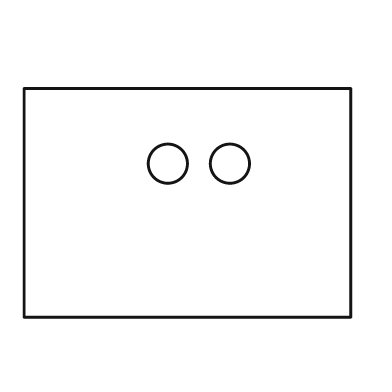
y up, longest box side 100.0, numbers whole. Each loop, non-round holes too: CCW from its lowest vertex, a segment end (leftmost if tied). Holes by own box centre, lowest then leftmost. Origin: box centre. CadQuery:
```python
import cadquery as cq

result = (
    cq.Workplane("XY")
    .moveTo(-50.0, -35.0)
    .lineTo(50.0, -35.0)
    .lineTo(50.0, 35.0)
    .lineTo(-50.0, 35.0)
    .close()
    .moveTo(-6.0, 12.0)
    .circle(6.0)
    .moveTo(13.0, 12.0)
    .circle(6.0)
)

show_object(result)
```